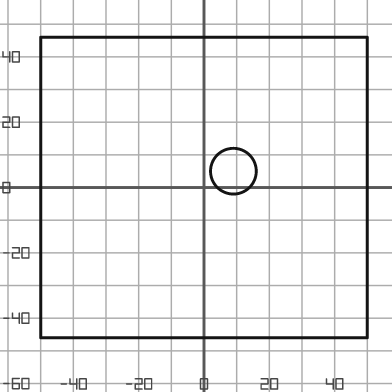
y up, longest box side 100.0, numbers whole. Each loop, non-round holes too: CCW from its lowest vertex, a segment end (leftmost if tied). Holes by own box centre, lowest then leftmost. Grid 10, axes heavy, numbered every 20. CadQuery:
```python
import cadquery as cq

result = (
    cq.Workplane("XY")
    .moveTo(-50.0, -46.0)
    .lineTo(50.0, -46.0)
    .lineTo(50.0, 46.0)
    .lineTo(-50.0, 46.0)
    .close()
    .moveTo(9.0, 5.0)
    .circle(7.0)
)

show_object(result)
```